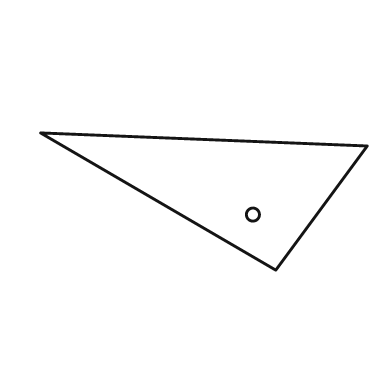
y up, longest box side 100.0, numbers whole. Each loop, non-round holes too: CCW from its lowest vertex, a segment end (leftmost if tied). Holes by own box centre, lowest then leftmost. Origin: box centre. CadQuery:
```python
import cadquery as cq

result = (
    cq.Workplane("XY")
    .moveTo(22.0, -21.0)
    .lineTo(50.0, 17.0)
    .lineTo(-50.0, 21.0)
    .close()
    .moveTo(15.0, -4.0)
    .circle(2.0)
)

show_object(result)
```